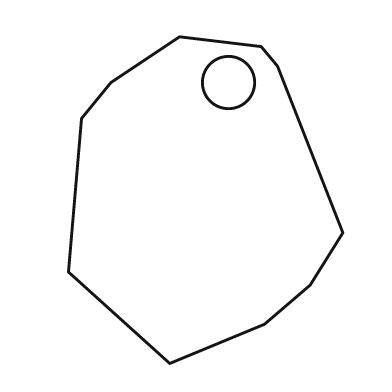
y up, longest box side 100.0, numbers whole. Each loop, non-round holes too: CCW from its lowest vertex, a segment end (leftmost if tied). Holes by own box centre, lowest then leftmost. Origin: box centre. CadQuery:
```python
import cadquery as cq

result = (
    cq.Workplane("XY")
    .moveTo(-11.0, -50.0)
    .lineTo(18.0, -38.0)
    .lineTo(32.0, -26.0)
    .lineTo(42.0, -10.0)
    .lineTo(22.0, 41.0)
    .lineTo(17.0, 47.0)
    .lineTo(-8.0, 50.0)
    .lineTo(-29.0, 36.0)
    .lineTo(-38.0, 25.0)
    .lineTo(-42.0, -22.0)
    .close()
    .moveTo(7.0, 36.0)
    .circle(8.0)
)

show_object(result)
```